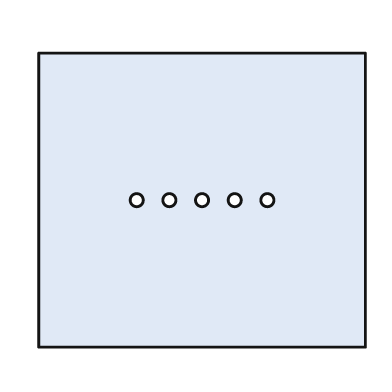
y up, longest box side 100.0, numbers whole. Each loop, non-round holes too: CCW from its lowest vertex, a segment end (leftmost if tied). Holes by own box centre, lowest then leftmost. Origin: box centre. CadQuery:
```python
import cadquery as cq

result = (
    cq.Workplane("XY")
    .moveTo(-50.0, -45.0)
    .lineTo(50.0, -45.0)
    .lineTo(50.0, 45.0)
    .lineTo(-50.0, 45.0)
    .close()
    .moveTo(-20.0, 0.0)
    .circle(2.0)
    .moveTo(-10.0, 0.0)
    .circle(2.0)
    .moveTo(0.0, 0.0)
    .circle(2.0)
    .moveTo(10.0, 0.0)
    .circle(2.0)
    .moveTo(20.0, 0.0)
    .circle(2.0)
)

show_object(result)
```